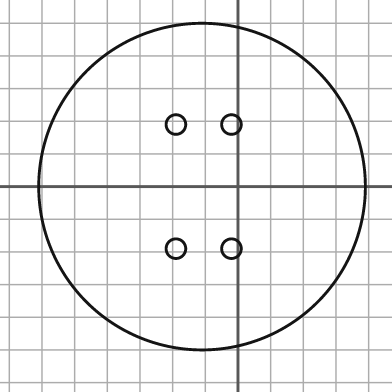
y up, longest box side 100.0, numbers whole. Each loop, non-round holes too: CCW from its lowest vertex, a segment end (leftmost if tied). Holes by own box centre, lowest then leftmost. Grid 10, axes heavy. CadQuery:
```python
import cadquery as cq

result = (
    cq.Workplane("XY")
    .moveTo(-11.0, 0.0)
    .circle(50.0)
    .moveTo(-19.0, -19.0)
    .circle(3.0)
    .moveTo(-2.0, -19.0)
    .circle(3.0)
    .moveTo(-19.0, 19.0)
    .circle(3.0)
    .moveTo(-2.0, 19.0)
    .circle(3.0)
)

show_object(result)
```